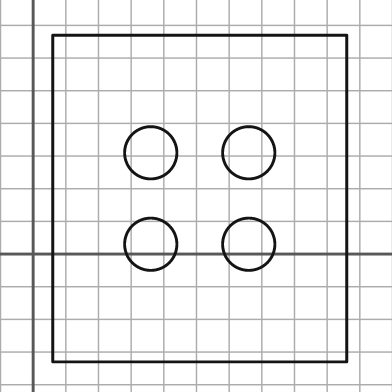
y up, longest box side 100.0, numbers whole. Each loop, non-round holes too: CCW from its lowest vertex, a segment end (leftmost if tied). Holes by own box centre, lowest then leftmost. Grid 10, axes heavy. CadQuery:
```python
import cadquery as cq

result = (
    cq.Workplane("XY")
    .moveTo(6.0, -33.0)
    .lineTo(96.0, -33.0)
    .lineTo(96.0, 67.0)
    .lineTo(6.0, 67.0)
    .close()
    .moveTo(36.0, 3.0)
    .circle(8.0)
    .moveTo(66.0, 3.0)
    .circle(8.0)
    .moveTo(36.0, 31.0)
    .circle(8.0)
    .moveTo(66.0, 31.0)
    .circle(8.0)
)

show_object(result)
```